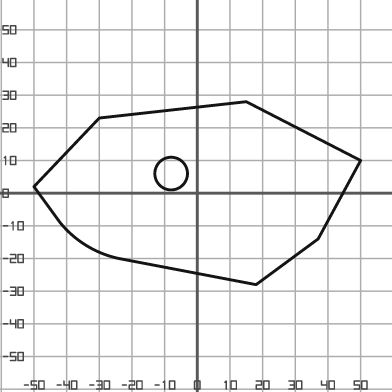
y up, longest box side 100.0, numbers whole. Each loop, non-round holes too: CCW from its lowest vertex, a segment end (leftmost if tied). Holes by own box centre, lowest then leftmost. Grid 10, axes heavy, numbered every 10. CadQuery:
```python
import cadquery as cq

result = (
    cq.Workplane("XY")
    .moveTo(18.0, -28.0)
    .lineTo(37.0, -14.0)
    .lineTo(50.0, 10.0)
    .lineTo(15.0, 28.0)
    .lineTo(-30.0, 23.0)
    .lineTo(-50.0, 2.0)
    .lineTo(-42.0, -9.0)
    .threePointArc((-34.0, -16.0), (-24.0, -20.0))
    .close()
    .moveTo(-8.0, 6.0)
    .circle(5.0)
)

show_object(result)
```